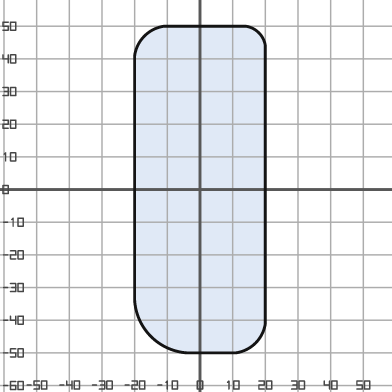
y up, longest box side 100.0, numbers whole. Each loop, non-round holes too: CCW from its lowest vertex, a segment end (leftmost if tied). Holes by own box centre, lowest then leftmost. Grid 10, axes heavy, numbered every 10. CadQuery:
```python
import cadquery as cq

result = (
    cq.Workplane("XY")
    .moveTo(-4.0, -50.0)
    .lineTo(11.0, -50.0)
    .threePointArc((17.0, -47.0), (20.0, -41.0))
    .lineTo(20.0, 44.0)
    .threePointArc((18.0, 48.0), (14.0, 50.0))
    .lineTo(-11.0, 50.0)
    .threePointArc((-17.0, 47.0), (-20.0, 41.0))
    .lineTo(-20.0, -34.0)
    .threePointArc((-15.0, -45.0), (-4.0, -50.0))
    .close()
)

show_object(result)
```